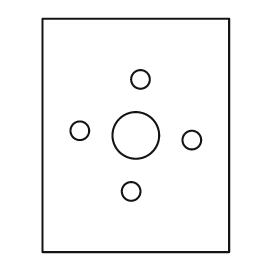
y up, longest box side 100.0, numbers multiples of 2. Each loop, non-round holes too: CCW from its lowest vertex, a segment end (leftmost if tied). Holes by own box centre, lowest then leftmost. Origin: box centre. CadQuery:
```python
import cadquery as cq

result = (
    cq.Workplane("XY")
    .moveTo(-40.0, -50.0)
    .lineTo(40.0, -50.0)
    .lineTo(40.0, 50.0)
    .lineTo(-40.0, 50.0)
    .close()
    .moveTo(-2.0, -24.0)
    .circle(4.0)
    .moveTo(24.0, -2.0)
    .circle(4.0)
    .moveTo(0.0, 0.0)
    .circle(10.0)
    .moveTo(-24.0, 2.0)
    .circle(4.0)
    .moveTo(2.0, 24.0)
    .circle(4.0)
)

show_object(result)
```